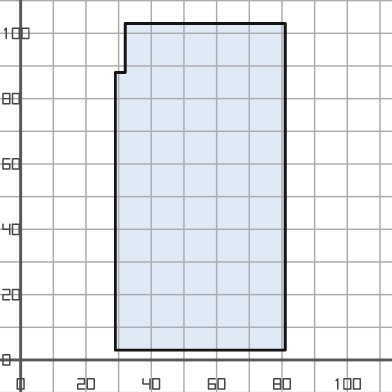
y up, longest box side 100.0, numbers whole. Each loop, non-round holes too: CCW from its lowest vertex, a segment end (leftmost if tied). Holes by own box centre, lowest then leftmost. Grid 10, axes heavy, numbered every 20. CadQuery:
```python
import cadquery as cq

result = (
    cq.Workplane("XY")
    .moveTo(29.0, 3.0)
    .lineTo(81.0, 3.0)
    .lineTo(81.0, 103.0)
    .lineTo(32.0, 103.0)
    .lineTo(32.0, 88.0)
    .lineTo(29.0, 88.0)
    .close()
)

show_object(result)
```